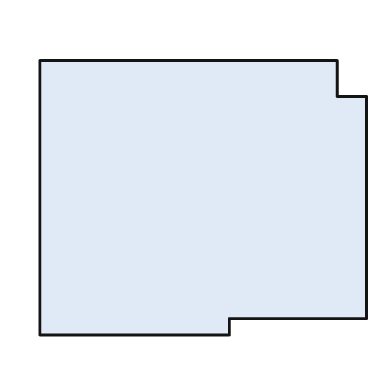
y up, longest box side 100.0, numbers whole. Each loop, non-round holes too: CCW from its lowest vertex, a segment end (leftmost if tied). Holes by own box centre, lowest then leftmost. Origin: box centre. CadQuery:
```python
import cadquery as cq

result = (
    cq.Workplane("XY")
    .moveTo(-50.0, -42.0)
    .lineTo(8.0, -42.0)
    .lineTo(8.0, -37.0)
    .lineTo(50.0, -37.0)
    .lineTo(50.0, 31.0)
    .lineTo(41.0, 31.0)
    .lineTo(41.0, 42.0)
    .lineTo(-50.0, 42.0)
    .close()
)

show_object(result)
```